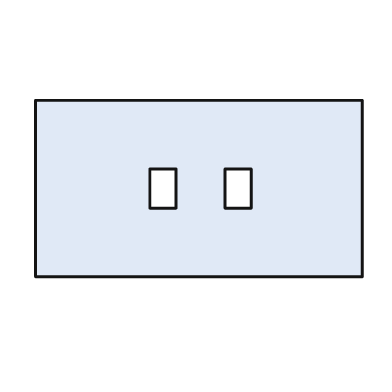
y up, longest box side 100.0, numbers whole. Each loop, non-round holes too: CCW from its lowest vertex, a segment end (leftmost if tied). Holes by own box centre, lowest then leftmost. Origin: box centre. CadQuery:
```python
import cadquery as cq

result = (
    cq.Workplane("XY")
    .moveTo(-50.0, -27.0)
    .lineTo(50.0, -27.0)
    .lineTo(50.0, 27.0)
    .lineTo(-50.0, 27.0)
    .close()
    .moveTo(-15.0, -6.0)
    .lineTo(-7.0, -6.0)
    .lineTo(-7.0, 6.0)
    .lineTo(-15.0, 6.0)
    .close()
    .moveTo(8.0, -6.0)
    .lineTo(16.0, -6.0)
    .lineTo(16.0, 6.0)
    .lineTo(8.0, 6.0)
    .close()
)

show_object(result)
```